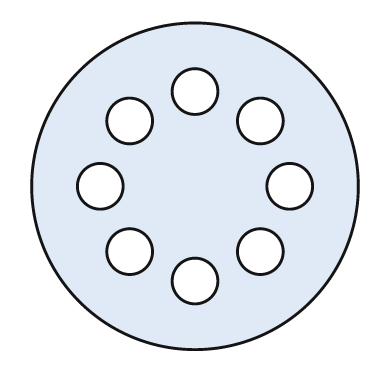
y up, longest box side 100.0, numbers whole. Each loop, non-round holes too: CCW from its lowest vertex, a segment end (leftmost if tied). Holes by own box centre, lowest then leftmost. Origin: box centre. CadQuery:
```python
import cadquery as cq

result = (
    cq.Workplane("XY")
    .moveTo(0.0, 0.0)
    .circle(50.0)
    .moveTo(0.0, -29.0)
    .circle(7.0)
    .moveTo(-20.0, -20.0)
    .circle(7.0)
    .moveTo(20.0, -20.0)
    .circle(7.0)
    .moveTo(-29.0, 0.0)
    .circle(7.0)
    .moveTo(29.0, 0.0)
    .circle(7.0)
    .moveTo(-20.0, 20.0)
    .circle(7.0)
    .moveTo(20.0, 20.0)
    .circle(7.0)
    .moveTo(0.0, 29.0)
    .circle(7.0)
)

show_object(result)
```